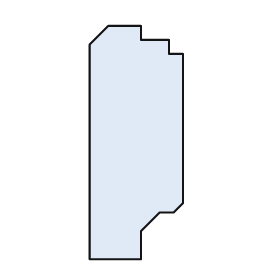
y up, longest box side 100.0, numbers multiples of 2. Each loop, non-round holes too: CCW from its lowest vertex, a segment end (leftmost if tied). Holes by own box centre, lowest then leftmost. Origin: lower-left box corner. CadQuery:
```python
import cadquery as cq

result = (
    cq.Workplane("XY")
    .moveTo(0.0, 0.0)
    .lineTo(22.0, 0.0)
    .lineTo(22.0, 12.0)
    .lineTo(30.0, 20.0)
    .lineTo(36.0, 20.0)
    .lineTo(40.0, 24.0)
    .lineTo(40.0, 88.0)
    .lineTo(34.0, 88.0)
    .lineTo(34.0, 94.0)
    .lineTo(22.0, 94.0)
    .lineTo(22.0, 100.0)
    .lineTo(8.0, 100.0)
    .lineTo(0.0, 92.0)
    .close()
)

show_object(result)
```